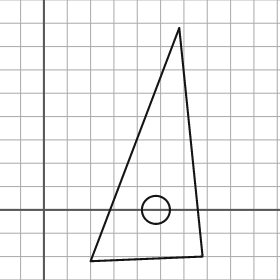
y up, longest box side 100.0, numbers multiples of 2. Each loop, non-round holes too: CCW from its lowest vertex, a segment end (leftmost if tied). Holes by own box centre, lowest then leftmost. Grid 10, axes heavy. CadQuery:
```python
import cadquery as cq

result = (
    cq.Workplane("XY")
    .moveTo(20.0, -22.0)
    .lineTo(68.0, -20.0)
    .lineTo(58.0, 78.0)
    .close()
    .moveTo(48.0, 0.0)
    .circle(6.0)
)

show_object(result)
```